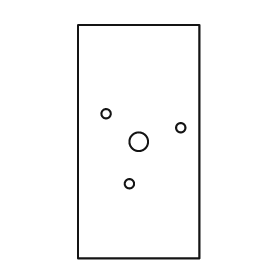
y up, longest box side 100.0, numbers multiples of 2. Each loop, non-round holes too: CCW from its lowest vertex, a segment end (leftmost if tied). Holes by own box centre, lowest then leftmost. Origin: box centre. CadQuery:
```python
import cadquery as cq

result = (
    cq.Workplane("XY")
    .moveTo(-26.0, -50.0)
    .lineTo(26.0, -50.0)
    .lineTo(26.0, 50.0)
    .lineTo(-26.0, 50.0)
    .close()
    .moveTo(-4.0, -18.0)
    .circle(2.0)
    .moveTo(0.0, 0.0)
    .circle(4.0)
    .moveTo(18.0, 6.0)
    .circle(2.0)
    .moveTo(-14.0, 12.0)
    .circle(2.0)
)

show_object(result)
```